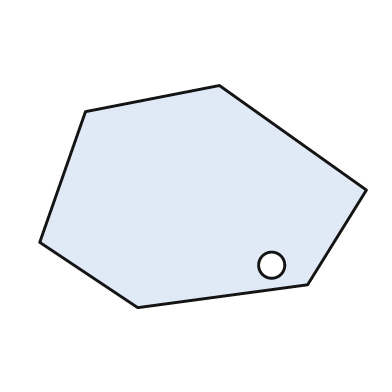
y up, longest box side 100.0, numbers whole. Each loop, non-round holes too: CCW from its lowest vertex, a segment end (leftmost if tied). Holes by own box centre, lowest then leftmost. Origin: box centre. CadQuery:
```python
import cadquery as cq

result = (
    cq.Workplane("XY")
    .moveTo(-20.0, -34.0)
    .lineTo(32.0, -27.0)
    .lineTo(50.0, 2.0)
    .lineTo(5.0, 34.0)
    .lineTo(-36.0, 26.0)
    .lineTo(-50.0, -14.0)
    .close()
    .moveTo(21.0, -21.0)
    .circle(4.0)
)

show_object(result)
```